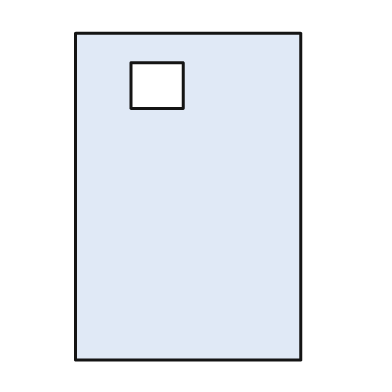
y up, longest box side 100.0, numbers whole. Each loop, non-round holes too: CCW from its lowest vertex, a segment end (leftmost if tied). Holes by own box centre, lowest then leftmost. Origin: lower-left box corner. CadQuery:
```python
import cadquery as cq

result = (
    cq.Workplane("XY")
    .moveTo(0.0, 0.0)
    .lineTo(69.0, 0.0)
    .lineTo(69.0, 100.0)
    .lineTo(0.0, 100.0)
    .close()
    .moveTo(17.0, 77.0)
    .lineTo(33.0, 77.0)
    .lineTo(33.0, 91.0)
    .lineTo(17.0, 91.0)
    .close()
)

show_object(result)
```